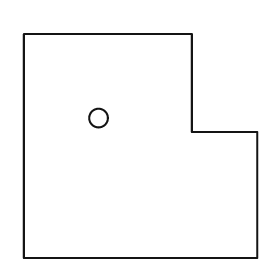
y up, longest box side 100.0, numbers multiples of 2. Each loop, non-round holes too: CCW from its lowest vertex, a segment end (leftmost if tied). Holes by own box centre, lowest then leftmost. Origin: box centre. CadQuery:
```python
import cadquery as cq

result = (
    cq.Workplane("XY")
    .moveTo(-50.0, -48.0)
    .lineTo(50.0, -48.0)
    .lineTo(50.0, 6.0)
    .lineTo(22.0, 6.0)
    .lineTo(22.0, 48.0)
    .lineTo(-50.0, 48.0)
    .close()
    .moveTo(-18.0, 12.0)
    .circle(4.0)
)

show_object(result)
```